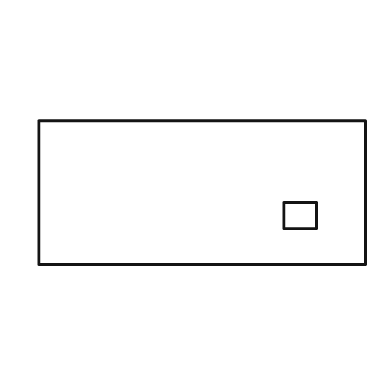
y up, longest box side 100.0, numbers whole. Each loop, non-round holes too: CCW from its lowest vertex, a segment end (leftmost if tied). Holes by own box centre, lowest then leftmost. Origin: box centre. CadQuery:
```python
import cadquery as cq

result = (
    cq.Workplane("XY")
    .moveTo(-50.0, -22.0)
    .lineTo(50.0, -22.0)
    .lineTo(50.0, 22.0)
    .lineTo(-50.0, 22.0)
    .close()
    .moveTo(25.0, -11.0)
    .lineTo(35.0, -11.0)
    .lineTo(35.0, -3.0)
    .lineTo(25.0, -3.0)
    .close()
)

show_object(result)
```